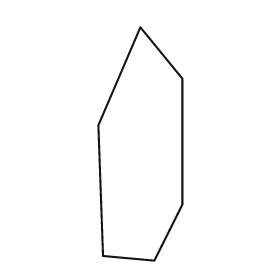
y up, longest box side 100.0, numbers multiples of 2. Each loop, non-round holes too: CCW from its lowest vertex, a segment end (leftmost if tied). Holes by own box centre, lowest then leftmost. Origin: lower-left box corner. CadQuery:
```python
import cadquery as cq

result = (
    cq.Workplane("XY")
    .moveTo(24.0, 0.0)
    .lineTo(36.0, 24.0)
    .lineTo(36.0, 78.0)
    .lineTo(18.0, 100.0)
    .lineTo(0.0, 58.0)
    .lineTo(2.0, 2.0)
    .close()
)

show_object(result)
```